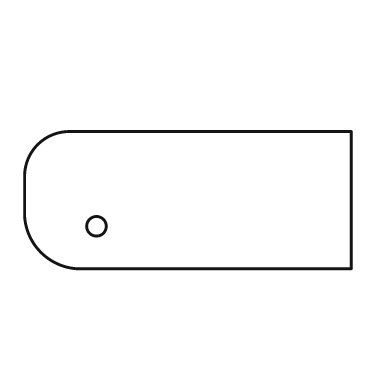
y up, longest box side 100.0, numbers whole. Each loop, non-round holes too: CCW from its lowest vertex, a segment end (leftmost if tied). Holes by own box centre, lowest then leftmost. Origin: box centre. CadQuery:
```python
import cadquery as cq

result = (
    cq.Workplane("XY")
    .moveTo(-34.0, -21.0)
    .lineTo(50.0, -21.0)
    .lineTo(50.0, 21.0)
    .lineTo(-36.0, 21.0)
    .threePointArc((-46.0, 17.0), (-50.0, 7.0))
    .lineTo(-50.0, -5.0)
    .threePointArc((-45.0, -16.0), (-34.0, -21.0))
    .close()
    .moveTo(-28.0, -8.0)
    .circle(3.0)
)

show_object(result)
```